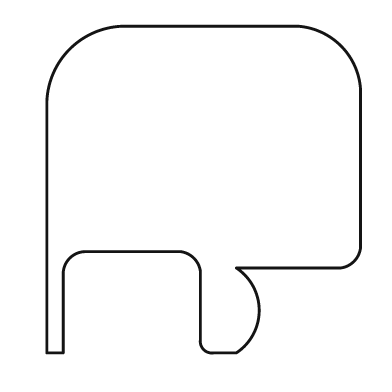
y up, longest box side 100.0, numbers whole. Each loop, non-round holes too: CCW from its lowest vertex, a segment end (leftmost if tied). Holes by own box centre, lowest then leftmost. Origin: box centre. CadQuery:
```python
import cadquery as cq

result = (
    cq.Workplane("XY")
    .moveTo(-48.0, -50.0)
    .lineTo(-43.0, -50.0)
    .lineTo(-43.0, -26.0)
    .threePointArc((-41.0, -21.0), (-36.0, -19.0))
    .lineTo(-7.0, -19.0)
    .threePointArc((-3.0, -21.0), (-1.0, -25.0))
    .lineTo(-1.0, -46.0)
    .threePointArc((0.0, -49.0), (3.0, -50.0))
    .lineTo(10.0, -50.0)
    .threePointArc((17.0, -37.0), (10.0, -24.0))
    .lineTo(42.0, -24.0)
    .threePointArc((46.0, -22.0), (48.0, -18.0))
    .lineTo(48.0, 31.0)
    .threePointArc((42.0, 44.0), (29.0, 50.0))
    .lineTo(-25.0, 50.0)
    .threePointArc((-41.0, 43.0), (-48.0, 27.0))
    .close()
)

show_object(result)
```